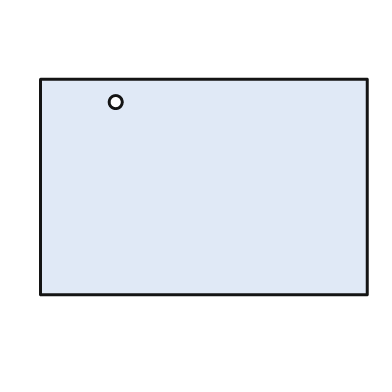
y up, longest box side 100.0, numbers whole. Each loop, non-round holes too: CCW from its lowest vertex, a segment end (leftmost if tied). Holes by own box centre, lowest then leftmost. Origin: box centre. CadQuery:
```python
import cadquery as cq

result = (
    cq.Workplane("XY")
    .moveTo(-50.0, -33.0)
    .lineTo(50.0, -33.0)
    .lineTo(50.0, 33.0)
    .lineTo(-50.0, 33.0)
    .close()
    .moveTo(-27.0, 26.0)
    .circle(2.0)
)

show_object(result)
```